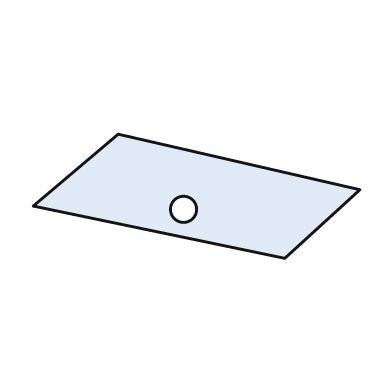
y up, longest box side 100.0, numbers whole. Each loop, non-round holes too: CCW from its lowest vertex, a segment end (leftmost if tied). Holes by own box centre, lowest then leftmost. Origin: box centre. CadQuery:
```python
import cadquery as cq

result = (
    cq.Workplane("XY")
    .moveTo(27.0, -19.0)
    .lineTo(50.0, 2.0)
    .lineTo(-24.0, 19.0)
    .lineTo(-50.0, -3.0)
    .close()
    .moveTo(-4.0, -4.0)
    .circle(4.0)
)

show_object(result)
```